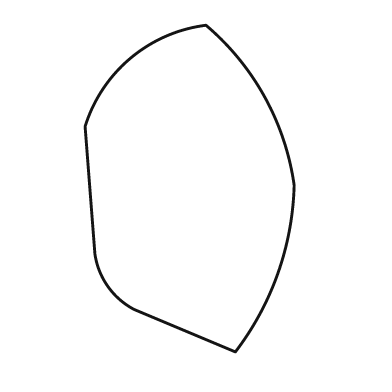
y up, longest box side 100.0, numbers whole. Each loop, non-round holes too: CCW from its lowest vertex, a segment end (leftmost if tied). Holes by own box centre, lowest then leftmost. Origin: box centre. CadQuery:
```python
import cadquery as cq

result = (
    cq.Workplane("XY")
    .moveTo(14.0, -50.0)
    .threePointArc((27.0, -26.0), (32.0, 1.0))
    .threePointArc((23.0, 28.0), (5.0, 50.0))
    .threePointArc((-18.0, 40.0), (-32.0, 19.0))
    .lineTo(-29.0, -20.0)
    .threePointArc((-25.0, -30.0), (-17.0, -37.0))
    .close()
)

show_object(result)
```